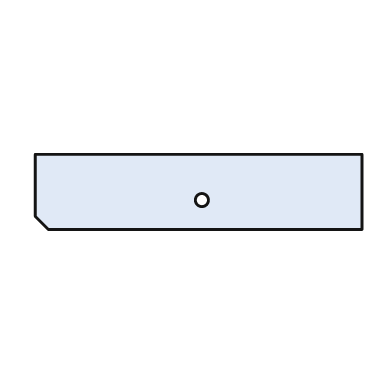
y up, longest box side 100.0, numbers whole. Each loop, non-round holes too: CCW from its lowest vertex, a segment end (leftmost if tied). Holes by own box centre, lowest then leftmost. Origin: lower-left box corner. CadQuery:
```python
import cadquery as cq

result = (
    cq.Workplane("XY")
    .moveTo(4.0, 0.0)
    .lineTo(100.0, 0.0)
    .lineTo(100.0, 23.0)
    .lineTo(0.0, 23.0)
    .lineTo(0.0, 4.0)
    .close()
    .moveTo(51.0, 9.0)
    .circle(2.0)
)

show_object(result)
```